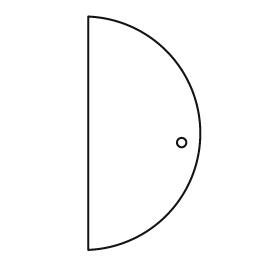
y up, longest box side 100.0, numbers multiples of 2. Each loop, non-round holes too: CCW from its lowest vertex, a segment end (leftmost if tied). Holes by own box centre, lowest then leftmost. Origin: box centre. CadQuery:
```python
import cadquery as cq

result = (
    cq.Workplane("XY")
    .moveTo(-24.0, -50.0)
    .threePointArc((24.0, 0.0), (-24.0, 50.0))
    .close()
    .moveTo(16.0, -4.0)
    .circle(2.0)
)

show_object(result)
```